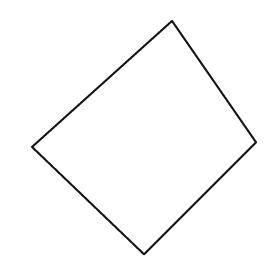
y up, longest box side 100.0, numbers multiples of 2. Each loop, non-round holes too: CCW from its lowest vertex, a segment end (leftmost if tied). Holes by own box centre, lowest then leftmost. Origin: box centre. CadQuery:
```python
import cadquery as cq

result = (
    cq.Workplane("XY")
    .moveTo(0.0, -50.0)
    .lineTo(48.0, -2.0)
    .lineTo(12.0, 50.0)
    .lineTo(-48.0, -4.0)
    .close()
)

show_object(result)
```